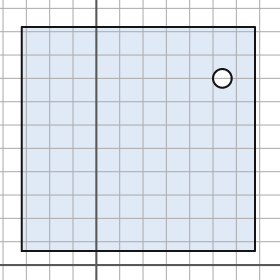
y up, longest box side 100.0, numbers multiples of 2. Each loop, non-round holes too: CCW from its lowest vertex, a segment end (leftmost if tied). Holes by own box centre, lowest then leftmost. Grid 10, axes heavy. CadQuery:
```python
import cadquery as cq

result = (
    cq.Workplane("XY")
    .moveTo(-32.0, 6.0)
    .lineTo(68.0, 6.0)
    .lineTo(68.0, 102.0)
    .lineTo(-32.0, 102.0)
    .close()
    .moveTo(54.0, 80.0)
    .circle(4.0)
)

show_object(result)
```